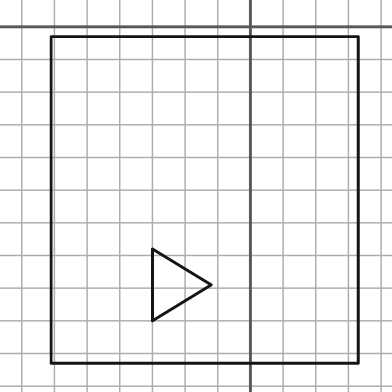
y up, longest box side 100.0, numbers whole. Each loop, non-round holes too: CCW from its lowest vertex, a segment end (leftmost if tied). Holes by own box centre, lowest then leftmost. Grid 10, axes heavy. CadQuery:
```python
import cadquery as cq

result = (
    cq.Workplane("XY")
    .moveTo(-61.0, -103.0)
    .lineTo(33.0, -103.0)
    .lineTo(33.0, -3.0)
    .lineTo(-61.0, -3.0)
    .close()
    .moveTo(-30.0, -90.0)
    .lineTo(-12.0, -79.0)
    .lineTo(-30.0, -68.0)
    .close()
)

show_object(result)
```